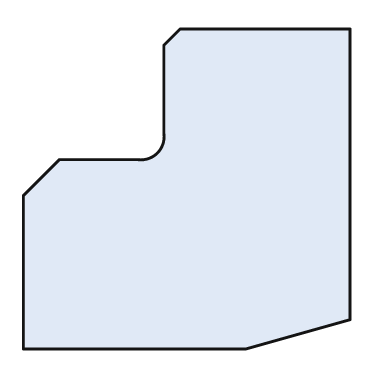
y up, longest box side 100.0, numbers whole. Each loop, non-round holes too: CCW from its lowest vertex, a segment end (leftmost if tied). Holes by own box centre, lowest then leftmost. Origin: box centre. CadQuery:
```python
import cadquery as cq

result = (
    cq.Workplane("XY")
    .moveTo(-50.0, -49.0)
    .lineTo(18.0, -49.0)
    .lineTo(50.0, -40.0)
    .lineTo(50.0, 49.0)
    .lineTo(-2.0, 49.0)
    .lineTo(-7.0, 44.0)
    .lineTo(-7.0, 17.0)
    .threePointArc((-9.0, 11.0), (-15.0, 9.0))
    .lineTo(-39.0, 9.0)
    .lineTo(-50.0, -2.0)
    .close()
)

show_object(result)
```